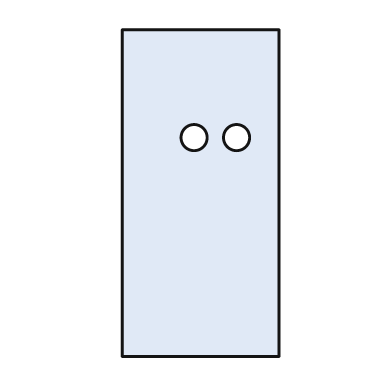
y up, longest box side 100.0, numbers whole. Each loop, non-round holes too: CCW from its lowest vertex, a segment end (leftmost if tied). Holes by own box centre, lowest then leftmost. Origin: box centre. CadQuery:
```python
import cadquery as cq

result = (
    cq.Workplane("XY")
    .moveTo(-24.0, -50.0)
    .lineTo(24.0, -50.0)
    .lineTo(24.0, 50.0)
    .lineTo(-24.0, 50.0)
    .close()
    .moveTo(-2.0, 17.0)
    .circle(4.0)
    .moveTo(11.0, 17.0)
    .circle(4.0)
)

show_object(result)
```